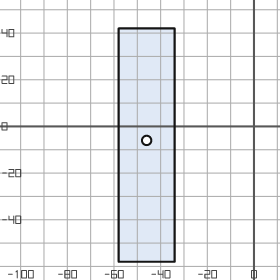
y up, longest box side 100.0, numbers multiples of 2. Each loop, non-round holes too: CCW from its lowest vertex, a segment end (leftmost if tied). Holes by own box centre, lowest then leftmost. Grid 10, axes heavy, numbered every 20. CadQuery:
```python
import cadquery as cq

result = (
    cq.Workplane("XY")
    .moveTo(-58.0, -58.0)
    .lineTo(-34.0, -58.0)
    .lineTo(-34.0, 42.0)
    .lineTo(-58.0, 42.0)
    .close()
    .moveTo(-46.0, -6.0)
    .circle(2.0)
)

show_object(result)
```